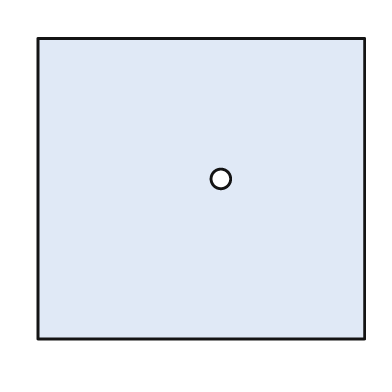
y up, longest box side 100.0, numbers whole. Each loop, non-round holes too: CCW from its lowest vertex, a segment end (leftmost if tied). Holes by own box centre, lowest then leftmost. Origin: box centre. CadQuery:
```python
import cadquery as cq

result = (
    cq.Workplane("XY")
    .moveTo(-50.0, -46.0)
    .lineTo(50.0, -46.0)
    .lineTo(50.0, 46.0)
    .lineTo(-50.0, 46.0)
    .close()
    .moveTo(6.0, 3.0)
    .circle(3.0)
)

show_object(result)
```